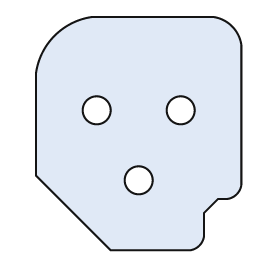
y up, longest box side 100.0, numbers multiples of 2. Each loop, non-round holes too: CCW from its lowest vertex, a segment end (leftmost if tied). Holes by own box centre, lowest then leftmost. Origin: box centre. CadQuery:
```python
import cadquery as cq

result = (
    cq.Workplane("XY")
    .moveTo(-12.0, -50.0)
    .lineTo(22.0, -50.0)
    .threePointArc((26.0, -48.0), (28.0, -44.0))
    .lineTo(28.0, -34.0)
    .lineTo(34.0, -28.0)
    .lineTo(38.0, -28.0)
    .threePointArc((42.0, -26.0), (44.0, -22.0))
    .lineTo(44.0, 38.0)
    .threePointArc((40.0, 46.0), (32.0, 50.0))
    .lineTo(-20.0, 50.0)
    .threePointArc((-36.0, 42.0), (-44.0, 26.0))
    .lineTo(-44.0, -18.0)
    .close()
    .moveTo(0.0, -20.0)
    .circle(6.0)
    .moveTo(-18.0, 10.0)
    .circle(6.0)
    .moveTo(18.0, 10.0)
    .circle(6.0)
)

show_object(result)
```